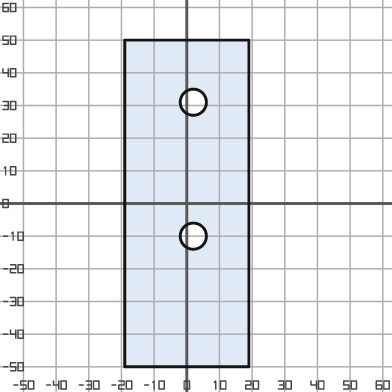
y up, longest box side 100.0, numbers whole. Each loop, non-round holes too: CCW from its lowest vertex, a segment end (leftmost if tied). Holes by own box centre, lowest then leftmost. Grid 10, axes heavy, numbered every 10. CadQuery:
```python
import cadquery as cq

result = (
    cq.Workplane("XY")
    .moveTo(-19.0, -50.0)
    .lineTo(19.0, -50.0)
    .lineTo(19.0, 50.0)
    .lineTo(-19.0, 50.0)
    .close()
    .moveTo(2.0, -10.0)
    .circle(4.0)
    .moveTo(2.0, 31.0)
    .circle(4.0)
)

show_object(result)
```